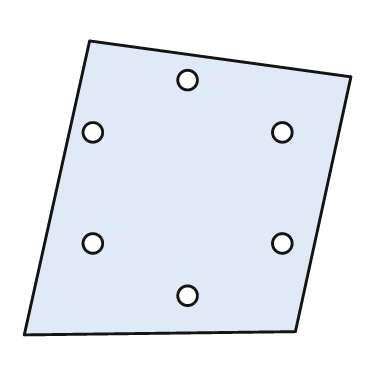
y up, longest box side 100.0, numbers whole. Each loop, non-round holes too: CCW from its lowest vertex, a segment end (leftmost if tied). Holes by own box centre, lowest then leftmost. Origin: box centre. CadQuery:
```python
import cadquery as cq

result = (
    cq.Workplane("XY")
    .moveTo(-50.0, -45.0)
    .lineTo(33.0, -44.0)
    .lineTo(50.0, 34.0)
    .lineTo(-30.0, 45.0)
    .close()
    .moveTo(0.0, -33.0)
    .circle(3.0)
    .moveTo(-29.0, -17.0)
    .circle(3.0)
    .moveTo(29.0, -17.0)
    .circle(3.0)
    .moveTo(-29.0, 17.0)
    .circle(3.0)
    .moveTo(29.0, 17.0)
    .circle(3.0)
    .moveTo(0.0, 33.0)
    .circle(3.0)
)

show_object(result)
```